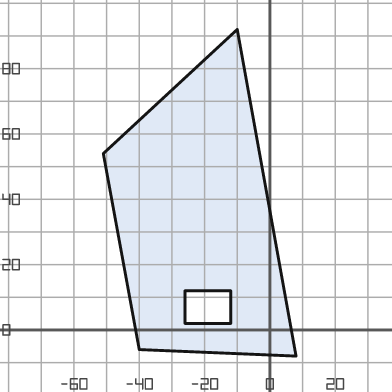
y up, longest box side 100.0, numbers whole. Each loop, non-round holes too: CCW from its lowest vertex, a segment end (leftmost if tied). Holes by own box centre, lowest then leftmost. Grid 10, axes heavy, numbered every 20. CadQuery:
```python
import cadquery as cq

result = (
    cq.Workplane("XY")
    .moveTo(8.0, -8.0)
    .lineTo(-10.0, 92.0)
    .lineTo(-51.0, 54.0)
    .lineTo(-40.0, -6.0)
    .close()
    .moveTo(-26.0, 2.0)
    .lineTo(-12.0, 2.0)
    .lineTo(-12.0, 12.0)
    .lineTo(-26.0, 12.0)
    .close()
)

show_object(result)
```